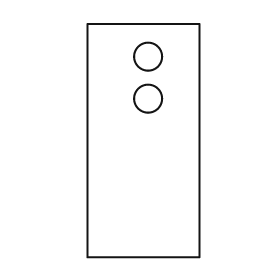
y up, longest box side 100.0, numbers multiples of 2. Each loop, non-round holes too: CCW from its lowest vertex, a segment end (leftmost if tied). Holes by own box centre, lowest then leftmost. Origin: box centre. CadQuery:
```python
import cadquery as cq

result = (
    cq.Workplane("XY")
    .moveTo(-24.0, -50.0)
    .lineTo(24.0, -50.0)
    .lineTo(24.0, 50.0)
    .lineTo(-24.0, 50.0)
    .close()
    .moveTo(2.0, 18.0)
    .circle(6.0)
    .moveTo(2.0, 36.0)
    .circle(6.0)
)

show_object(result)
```